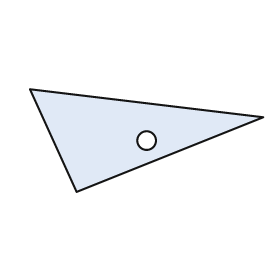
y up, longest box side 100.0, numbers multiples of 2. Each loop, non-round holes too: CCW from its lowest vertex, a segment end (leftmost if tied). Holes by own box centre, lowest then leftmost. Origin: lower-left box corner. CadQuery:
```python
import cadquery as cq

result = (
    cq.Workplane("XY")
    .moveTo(20.0, 0.0)
    .lineTo(100.0, 32.0)
    .lineTo(0.0, 44.0)
    .close()
    .moveTo(50.0, 22.0)
    .circle(4.0)
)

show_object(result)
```